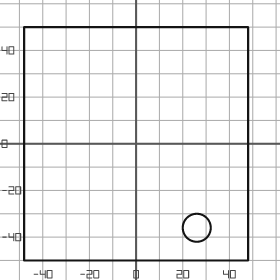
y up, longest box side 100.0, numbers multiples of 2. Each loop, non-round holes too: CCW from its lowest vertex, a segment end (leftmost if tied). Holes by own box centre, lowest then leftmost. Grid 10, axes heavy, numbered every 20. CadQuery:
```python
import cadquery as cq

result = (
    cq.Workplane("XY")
    .moveTo(-48.0, -50.0)
    .lineTo(48.0, -50.0)
    .lineTo(48.0, 50.0)
    .lineTo(-48.0, 50.0)
    .close()
    .moveTo(26.0, -36.0)
    .circle(6.0)
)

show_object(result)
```